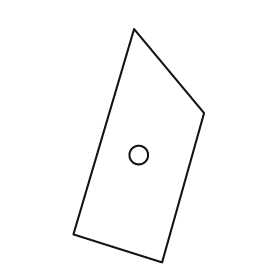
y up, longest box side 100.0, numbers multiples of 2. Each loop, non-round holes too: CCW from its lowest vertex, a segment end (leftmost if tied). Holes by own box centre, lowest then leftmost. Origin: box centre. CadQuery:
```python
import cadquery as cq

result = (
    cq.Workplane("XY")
    .moveTo(10.0, -50.0)
    .lineTo(28.0, 14.0)
    .lineTo(-2.0, 50.0)
    .lineTo(-28.0, -38.0)
    .close()
    .moveTo(0.0, -4.0)
    .circle(4.0)
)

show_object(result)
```